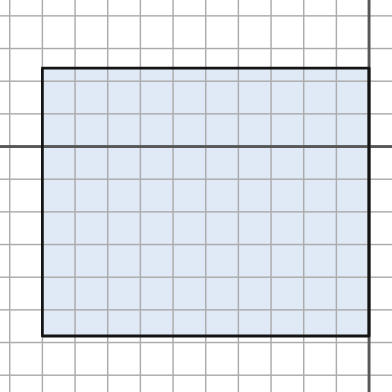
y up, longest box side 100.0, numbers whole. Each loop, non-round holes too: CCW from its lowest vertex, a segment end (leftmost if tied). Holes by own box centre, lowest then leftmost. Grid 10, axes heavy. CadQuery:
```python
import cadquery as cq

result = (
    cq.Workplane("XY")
    .moveTo(-100.0, -58.0)
    .lineTo(0.0, -58.0)
    .lineTo(0.0, 24.0)
    .lineTo(-100.0, 24.0)
    .close()
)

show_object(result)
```